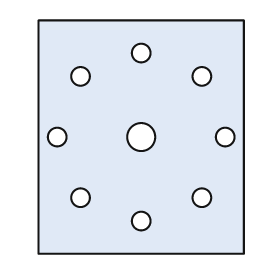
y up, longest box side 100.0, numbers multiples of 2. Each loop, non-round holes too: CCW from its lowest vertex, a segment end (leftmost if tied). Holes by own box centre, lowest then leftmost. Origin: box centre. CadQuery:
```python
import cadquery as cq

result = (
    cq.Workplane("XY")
    .moveTo(-44.0, -50.0)
    .lineTo(44.0, -50.0)
    .lineTo(44.0, 50.0)
    .lineTo(-44.0, 50.0)
    .close()
    .moveTo(0.0, -36.0)
    .circle(4.0)
    .moveTo(-26.0, -26.0)
    .circle(4.0)
    .moveTo(26.0, -26.0)
    .circle(4.0)
    .moveTo(-36.0, 0.0)
    .circle(4.0)
    .moveTo(0.0, 0.0)
    .circle(6.0)
    .moveTo(36.0, 0.0)
    .circle(4.0)
    .moveTo(-26.0, 26.0)
    .circle(4.0)
    .moveTo(26.0, 26.0)
    .circle(4.0)
    .moveTo(0.0, 36.0)
    .circle(4.0)
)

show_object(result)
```